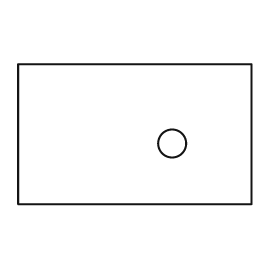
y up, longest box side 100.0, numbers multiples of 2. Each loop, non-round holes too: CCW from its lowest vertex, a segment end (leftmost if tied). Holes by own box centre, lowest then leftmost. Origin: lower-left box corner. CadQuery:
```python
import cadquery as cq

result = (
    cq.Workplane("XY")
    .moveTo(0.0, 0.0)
    .lineTo(100.0, 0.0)
    .lineTo(100.0, 60.0)
    .lineTo(0.0, 60.0)
    .close()
    .moveTo(66.0, 26.0)
    .circle(6.0)
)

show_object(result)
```